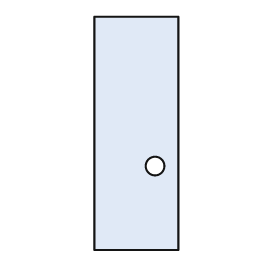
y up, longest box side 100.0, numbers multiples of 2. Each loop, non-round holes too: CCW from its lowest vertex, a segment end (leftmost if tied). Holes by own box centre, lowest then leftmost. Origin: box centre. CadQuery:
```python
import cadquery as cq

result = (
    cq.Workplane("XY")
    .moveTo(-18.0, -50.0)
    .lineTo(18.0, -50.0)
    .lineTo(18.0, 50.0)
    .lineTo(-18.0, 50.0)
    .close()
    .moveTo(8.0, -14.0)
    .circle(4.0)
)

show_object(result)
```